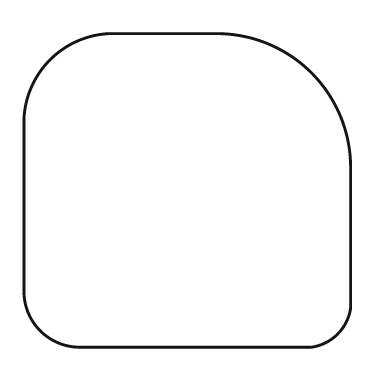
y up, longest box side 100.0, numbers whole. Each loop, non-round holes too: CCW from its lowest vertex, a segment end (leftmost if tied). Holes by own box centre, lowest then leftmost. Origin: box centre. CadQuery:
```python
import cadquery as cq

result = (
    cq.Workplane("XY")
    .moveTo(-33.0, -48.0)
    .lineTo(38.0, -48.0)
    .threePointArc((46.0, -44.0), (50.0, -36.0))
    .lineTo(50.0, 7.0)
    .threePointArc((38.0, 36.0), (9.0, 48.0))
    .lineTo(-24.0, 48.0)
    .threePointArc((-42.0, 40.0), (-50.0, 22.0))
    .lineTo(-50.0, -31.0)
    .threePointArc((-45.0, -43.0), (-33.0, -48.0))
    .close()
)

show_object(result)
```